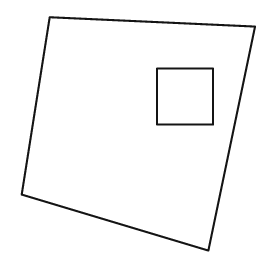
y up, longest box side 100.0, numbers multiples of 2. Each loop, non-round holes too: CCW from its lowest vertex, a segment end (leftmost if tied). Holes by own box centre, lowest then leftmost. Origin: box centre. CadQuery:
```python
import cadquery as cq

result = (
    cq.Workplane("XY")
    .moveTo(30.0, -50.0)
    .lineTo(50.0, 46.0)
    .lineTo(-38.0, 50.0)
    .lineTo(-50.0, -26.0)
    .close()
    .moveTo(8.0, 4.0)
    .lineTo(32.0, 4.0)
    .lineTo(32.0, 28.0)
    .lineTo(8.0, 28.0)
    .close()
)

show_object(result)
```